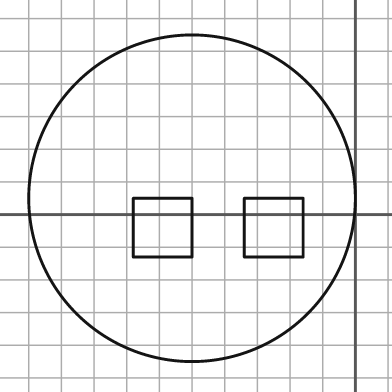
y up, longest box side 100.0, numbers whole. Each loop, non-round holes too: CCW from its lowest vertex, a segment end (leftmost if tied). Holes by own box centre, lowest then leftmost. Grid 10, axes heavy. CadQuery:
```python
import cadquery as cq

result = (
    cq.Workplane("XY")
    .moveTo(-50.0, 5.0)
    .circle(50.0)
    .moveTo(-68.0, -13.0)
    .lineTo(-50.0, -13.0)
    .lineTo(-50.0, 5.0)
    .lineTo(-68.0, 5.0)
    .close()
    .moveTo(-34.0, -13.0)
    .lineTo(-16.0, -13.0)
    .lineTo(-16.0, 5.0)
    .lineTo(-34.0, 5.0)
    .close()
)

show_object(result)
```